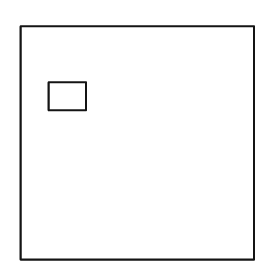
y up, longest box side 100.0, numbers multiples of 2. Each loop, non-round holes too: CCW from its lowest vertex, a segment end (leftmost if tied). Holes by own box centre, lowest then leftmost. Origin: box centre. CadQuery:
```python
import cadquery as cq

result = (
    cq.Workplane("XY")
    .moveTo(-50.0, -50.0)
    .lineTo(50.0, -50.0)
    .lineTo(50.0, 50.0)
    .lineTo(-50.0, 50.0)
    .close()
    .moveTo(-38.0, 14.0)
    .lineTo(-22.0, 14.0)
    .lineTo(-22.0, 26.0)
    .lineTo(-38.0, 26.0)
    .close()
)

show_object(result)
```